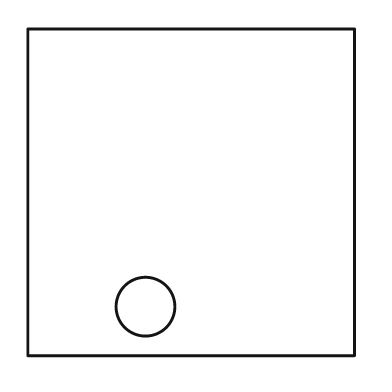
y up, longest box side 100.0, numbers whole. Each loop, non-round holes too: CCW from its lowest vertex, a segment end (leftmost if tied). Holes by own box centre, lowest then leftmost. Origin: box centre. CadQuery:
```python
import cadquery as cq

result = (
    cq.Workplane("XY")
    .moveTo(-50.0, -50.0)
    .lineTo(50.0, -50.0)
    .lineTo(50.0, 50.0)
    .lineTo(-50.0, 50.0)
    .close()
    .moveTo(-14.0, -35.0)
    .circle(9.0)
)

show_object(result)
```